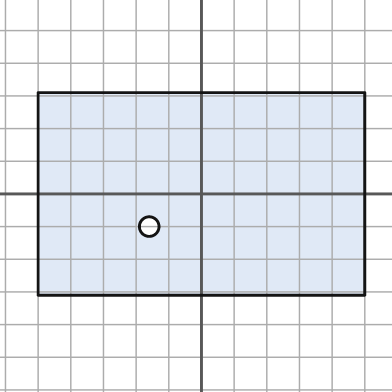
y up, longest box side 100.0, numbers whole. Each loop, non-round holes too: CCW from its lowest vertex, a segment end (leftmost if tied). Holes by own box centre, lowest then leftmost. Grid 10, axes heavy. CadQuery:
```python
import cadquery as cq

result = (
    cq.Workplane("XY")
    .moveTo(-50.0, -31.0)
    .lineTo(50.0, -31.0)
    .lineTo(50.0, 31.0)
    .lineTo(-50.0, 31.0)
    .close()
    .moveTo(-16.0, -10.0)
    .circle(3.0)
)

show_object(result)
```